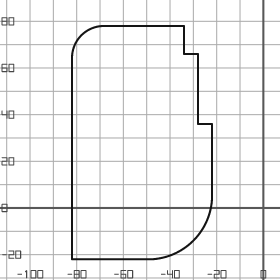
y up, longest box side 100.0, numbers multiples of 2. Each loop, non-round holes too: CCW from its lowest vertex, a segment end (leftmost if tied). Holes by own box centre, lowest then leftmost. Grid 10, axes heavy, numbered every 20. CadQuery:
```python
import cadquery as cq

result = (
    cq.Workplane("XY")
    .moveTo(-82.0, -22.0)
    .lineTo(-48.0, -22.0)
    .threePointArc((-30.0, -14.0), (-22.0, 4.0))
    .lineTo(-22.0, 36.0)
    .lineTo(-28.0, 36.0)
    .lineTo(-28.0, 66.0)
    .lineTo(-34.0, 66.0)
    .lineTo(-34.0, 78.0)
    .lineTo(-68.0, 78.0)
    .threePointArc((-78.0, 74.0), (-82.0, 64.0))
    .close()
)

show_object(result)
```